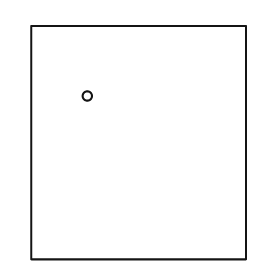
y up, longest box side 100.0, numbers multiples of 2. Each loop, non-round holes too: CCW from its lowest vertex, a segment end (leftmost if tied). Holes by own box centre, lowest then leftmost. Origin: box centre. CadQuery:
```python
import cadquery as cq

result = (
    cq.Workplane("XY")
    .moveTo(-46.0, -50.0)
    .lineTo(46.0, -50.0)
    .lineTo(46.0, 50.0)
    .lineTo(-46.0, 50.0)
    .close()
    .moveTo(-22.0, 20.0)
    .circle(2.0)
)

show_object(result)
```